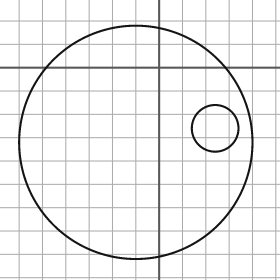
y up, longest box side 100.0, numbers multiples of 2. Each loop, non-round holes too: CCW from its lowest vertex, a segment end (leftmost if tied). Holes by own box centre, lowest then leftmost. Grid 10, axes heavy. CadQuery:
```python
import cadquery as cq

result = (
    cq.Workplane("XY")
    .moveTo(-10.0, -32.0)
    .circle(50.0)
    .moveTo(24.0, -26.0)
    .circle(10.0)
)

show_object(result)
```